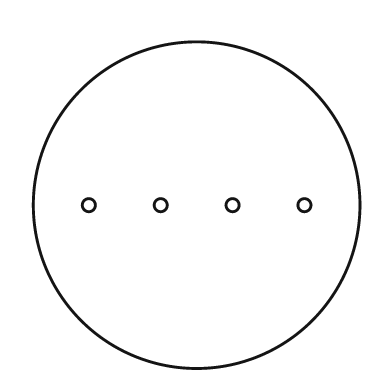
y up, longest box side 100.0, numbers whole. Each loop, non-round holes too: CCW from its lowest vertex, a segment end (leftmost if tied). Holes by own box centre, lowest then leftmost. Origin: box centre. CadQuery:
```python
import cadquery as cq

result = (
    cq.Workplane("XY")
    .moveTo(0.0, 0.0)
    .circle(50.0)
    .moveTo(-33.0, 0.0)
    .circle(2.0)
    .moveTo(-11.0, 0.0)
    .circle(2.0)
    .moveTo(11.0, 0.0)
    .circle(2.0)
    .moveTo(33.0, 0.0)
    .circle(2.0)
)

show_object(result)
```